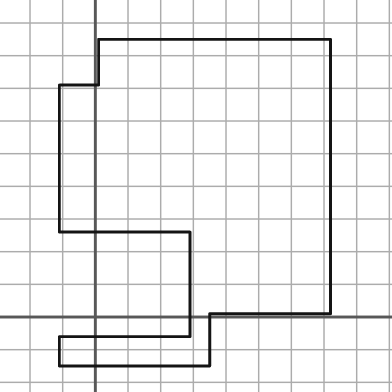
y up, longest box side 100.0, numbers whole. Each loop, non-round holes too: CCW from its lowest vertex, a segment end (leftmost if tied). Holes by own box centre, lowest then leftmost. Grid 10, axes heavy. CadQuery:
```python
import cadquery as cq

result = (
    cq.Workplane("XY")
    .moveTo(-11.0, -15.0)
    .lineTo(35.0, -15.0)
    .lineTo(35.0, 1.0)
    .lineTo(72.0, 1.0)
    .lineTo(72.0, 85.0)
    .lineTo(1.0, 85.0)
    .lineTo(1.0, 71.0)
    .lineTo(-11.0, 71.0)
    .lineTo(-11.0, 26.0)
    .lineTo(29.0, 26.0)
    .lineTo(29.0, -6.0)
    .lineTo(-11.0, -6.0)
    .close()
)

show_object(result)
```